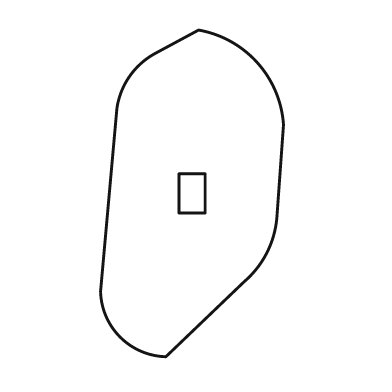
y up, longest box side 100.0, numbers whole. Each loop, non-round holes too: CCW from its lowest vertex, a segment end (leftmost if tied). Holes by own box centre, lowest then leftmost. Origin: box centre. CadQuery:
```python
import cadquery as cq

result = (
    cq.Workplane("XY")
    .moveTo(-8.0, -50.0)
    .lineTo(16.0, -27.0)
    .threePointArc((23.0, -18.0), (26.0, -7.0))
    .lineTo(28.0, 21.0)
    .threePointArc((20.0, 40.0), (2.0, 50.0))
    .lineTo(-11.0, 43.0)
    .threePointArc((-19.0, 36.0), (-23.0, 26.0))
    .lineTo(-28.0, -30.0)
    .threePointArc((-22.0, -44.0), (-8.0, -50.0))
    .close()
    .moveTo(-4.0, -6.0)
    .lineTo(4.0, -6.0)
    .lineTo(4.0, 6.0)
    .lineTo(-4.0, 6.0)
    .close()
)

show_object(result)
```